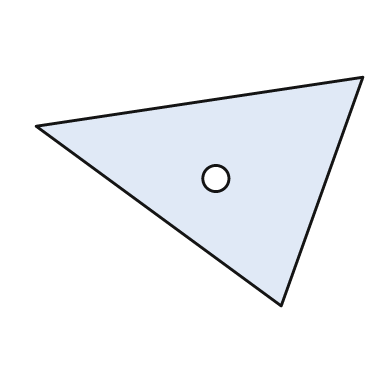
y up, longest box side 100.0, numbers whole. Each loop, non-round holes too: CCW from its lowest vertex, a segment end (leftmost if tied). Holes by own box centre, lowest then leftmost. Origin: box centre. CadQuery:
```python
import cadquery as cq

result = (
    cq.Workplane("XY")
    .moveTo(25.0, -35.0)
    .lineTo(50.0, 35.0)
    .lineTo(-50.0, 20.0)
    .close()
    .moveTo(5.0, 4.0)
    .circle(4.0)
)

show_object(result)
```